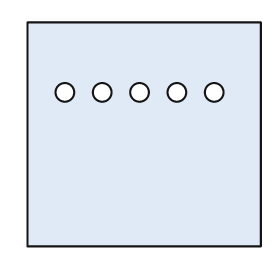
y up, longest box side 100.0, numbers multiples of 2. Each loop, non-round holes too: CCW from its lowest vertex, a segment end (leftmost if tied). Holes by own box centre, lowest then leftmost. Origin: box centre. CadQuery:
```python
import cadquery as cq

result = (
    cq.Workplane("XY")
    .moveTo(-50.0, -48.0)
    .lineTo(50.0, -48.0)
    .lineTo(50.0, 48.0)
    .lineTo(-50.0, 48.0)
    .close()
    .moveTo(-34.0, 18.0)
    .circle(4.0)
    .moveTo(-18.0, 18.0)
    .circle(4.0)
    .moveTo(-2.0, 18.0)
    .circle(4.0)
    .moveTo(14.0, 18.0)
    .circle(4.0)
    .moveTo(30.0, 18.0)
    .circle(4.0)
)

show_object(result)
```